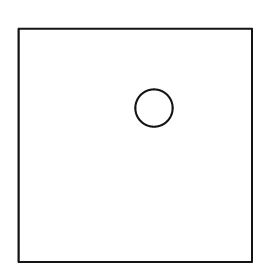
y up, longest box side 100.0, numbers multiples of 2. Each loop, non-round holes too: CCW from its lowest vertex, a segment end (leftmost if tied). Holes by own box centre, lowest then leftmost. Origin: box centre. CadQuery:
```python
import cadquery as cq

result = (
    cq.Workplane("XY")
    .moveTo(-50.0, -50.0)
    .lineTo(50.0, -50.0)
    .lineTo(50.0, 50.0)
    .lineTo(-50.0, 50.0)
    .close()
    .moveTo(8.0, 16.0)
    .circle(8.0)
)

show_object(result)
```